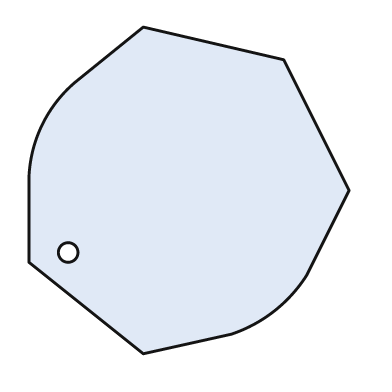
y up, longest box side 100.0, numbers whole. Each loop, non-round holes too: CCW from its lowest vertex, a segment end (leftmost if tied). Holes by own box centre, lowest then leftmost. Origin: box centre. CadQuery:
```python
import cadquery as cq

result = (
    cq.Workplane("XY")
    .moveTo(-14.0, -50.0)
    .lineTo(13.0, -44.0)
    .threePointArc((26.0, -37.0), (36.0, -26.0))
    .lineTo(49.0, 0.0)
    .lineTo(29.0, 40.0)
    .lineTo(-14.0, 50.0)
    .lineTo(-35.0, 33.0)
    .threePointArc((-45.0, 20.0), (-49.0, 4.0))
    .lineTo(-49.0, -22.0)
    .close()
    .moveTo(-37.0, -19.0)
    .circle(3.0)
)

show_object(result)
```